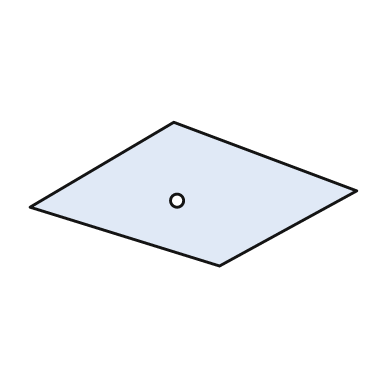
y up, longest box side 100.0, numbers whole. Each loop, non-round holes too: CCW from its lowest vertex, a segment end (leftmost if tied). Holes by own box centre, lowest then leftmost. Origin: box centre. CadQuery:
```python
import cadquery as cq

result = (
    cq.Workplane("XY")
    .moveTo(8.0, -22.0)
    .lineTo(50.0, 1.0)
    .lineTo(-6.0, 22.0)
    .lineTo(-50.0, -4.0)
    .close()
    .moveTo(-5.0, -2.0)
    .circle(2.0)
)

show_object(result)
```